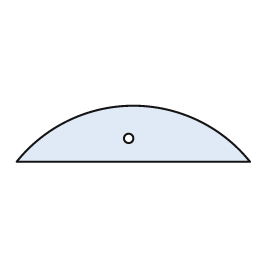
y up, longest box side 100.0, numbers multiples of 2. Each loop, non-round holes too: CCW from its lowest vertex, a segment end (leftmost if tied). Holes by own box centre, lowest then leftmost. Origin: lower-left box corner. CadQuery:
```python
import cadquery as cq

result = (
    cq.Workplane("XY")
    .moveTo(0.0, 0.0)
    .lineTo(100.0, 0.0)
    .threePointArc((50.0, 24.0), (0.0, 0.0))
    .close()
    .moveTo(48.0, 10.0)
    .circle(2.0)
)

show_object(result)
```